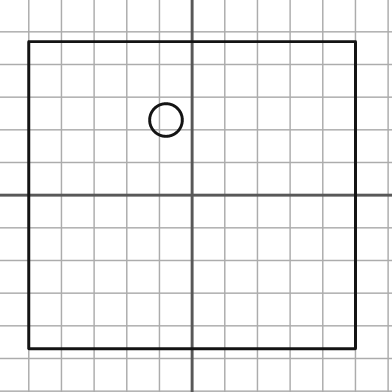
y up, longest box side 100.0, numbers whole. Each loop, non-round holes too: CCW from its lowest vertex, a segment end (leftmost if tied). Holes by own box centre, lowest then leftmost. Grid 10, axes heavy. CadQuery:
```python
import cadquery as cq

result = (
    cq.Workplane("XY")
    .moveTo(-50.0, -47.0)
    .lineTo(50.0, -47.0)
    .lineTo(50.0, 47.0)
    .lineTo(-50.0, 47.0)
    .close()
    .moveTo(-8.0, 23.0)
    .circle(5.0)
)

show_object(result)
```